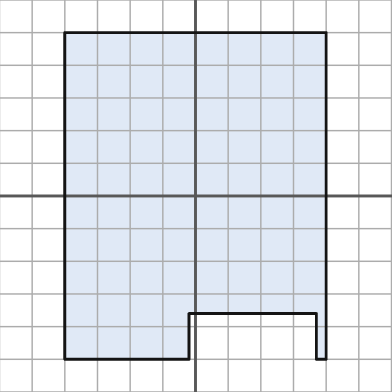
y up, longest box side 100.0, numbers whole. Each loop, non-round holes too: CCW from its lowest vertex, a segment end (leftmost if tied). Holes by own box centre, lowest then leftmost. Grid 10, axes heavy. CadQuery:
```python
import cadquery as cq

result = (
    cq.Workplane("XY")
    .moveTo(-40.0, -50.0)
    .lineTo(-2.0, -50.0)
    .lineTo(-2.0, -36.0)
    .lineTo(37.0, -36.0)
    .lineTo(37.0, -50.0)
    .lineTo(40.0, -50.0)
    .lineTo(40.0, 50.0)
    .lineTo(-40.0, 50.0)
    .close()
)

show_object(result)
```